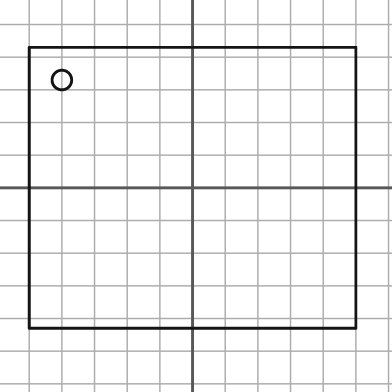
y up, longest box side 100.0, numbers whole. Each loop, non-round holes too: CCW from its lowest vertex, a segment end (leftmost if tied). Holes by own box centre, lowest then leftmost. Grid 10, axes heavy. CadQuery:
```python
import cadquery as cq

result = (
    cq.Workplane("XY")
    .moveTo(-50.0, -43.0)
    .lineTo(50.0, -43.0)
    .lineTo(50.0, 43.0)
    .lineTo(-50.0, 43.0)
    .close()
    .moveTo(-40.0, 33.0)
    .circle(3.0)
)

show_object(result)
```